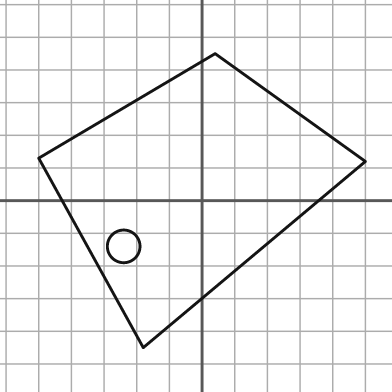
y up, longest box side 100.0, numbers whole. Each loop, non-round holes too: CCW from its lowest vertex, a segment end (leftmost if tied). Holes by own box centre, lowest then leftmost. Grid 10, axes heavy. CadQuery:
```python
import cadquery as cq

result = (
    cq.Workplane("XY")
    .moveTo(-18.0, -45.0)
    .lineTo(50.0, 12.0)
    .lineTo(4.0, 45.0)
    .lineTo(-50.0, 13.0)
    .close()
    .moveTo(-24.0, -14.0)
    .circle(5.0)
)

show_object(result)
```